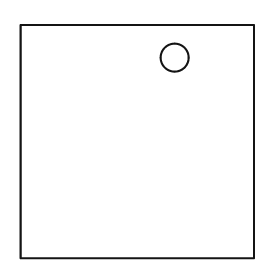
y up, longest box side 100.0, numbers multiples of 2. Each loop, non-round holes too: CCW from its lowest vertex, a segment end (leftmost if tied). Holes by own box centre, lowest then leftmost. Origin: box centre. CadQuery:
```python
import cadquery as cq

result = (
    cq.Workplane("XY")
    .moveTo(-50.0, -50.0)
    .lineTo(50.0, -50.0)
    .lineTo(50.0, 50.0)
    .lineTo(-50.0, 50.0)
    .close()
    .moveTo(16.0, 36.0)
    .circle(6.0)
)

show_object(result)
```